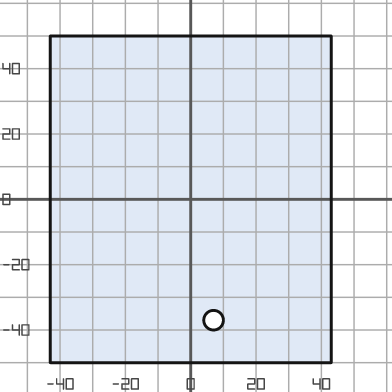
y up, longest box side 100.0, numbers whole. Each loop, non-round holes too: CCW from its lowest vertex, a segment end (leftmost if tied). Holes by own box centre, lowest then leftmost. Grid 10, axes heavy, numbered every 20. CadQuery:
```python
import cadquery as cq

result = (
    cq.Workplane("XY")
    .moveTo(-43.0, -50.0)
    .lineTo(43.0, -50.0)
    .lineTo(43.0, 50.0)
    .lineTo(-43.0, 50.0)
    .close()
    .moveTo(7.0, -37.0)
    .circle(3.0)
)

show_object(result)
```